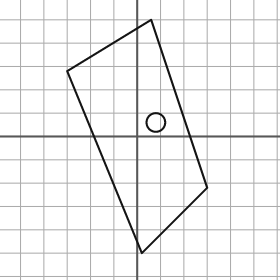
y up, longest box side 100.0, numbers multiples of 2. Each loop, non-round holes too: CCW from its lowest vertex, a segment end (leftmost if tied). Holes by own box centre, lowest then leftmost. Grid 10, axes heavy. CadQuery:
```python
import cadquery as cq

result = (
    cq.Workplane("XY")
    .moveTo(2.0, -50.0)
    .lineTo(30.0, -22.0)
    .lineTo(6.0, 50.0)
    .lineTo(-30.0, 28.0)
    .close()
    .moveTo(8.0, 6.0)
    .circle(4.0)
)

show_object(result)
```